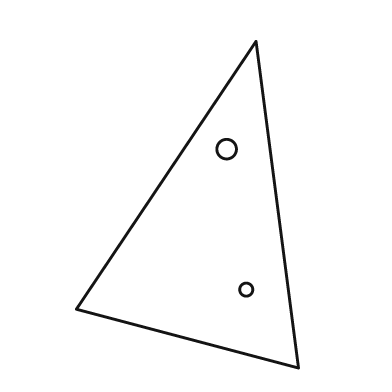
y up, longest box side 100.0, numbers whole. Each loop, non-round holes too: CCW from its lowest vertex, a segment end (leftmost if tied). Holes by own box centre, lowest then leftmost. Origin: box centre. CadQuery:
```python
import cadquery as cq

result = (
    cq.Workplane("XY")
    .moveTo(34.0, -50.0)
    .lineTo(21.0, 50.0)
    .lineTo(-34.0, -32.0)
    .close()
    .moveTo(18.0, -26.0)
    .circle(2.0)
    .moveTo(12.0, 17.0)
    .circle(3.0)
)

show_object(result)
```